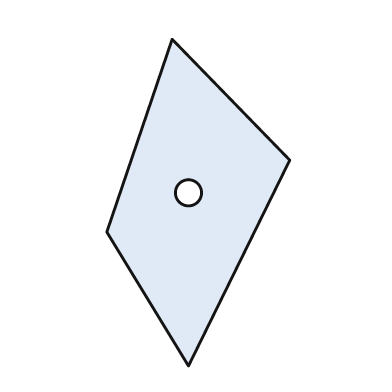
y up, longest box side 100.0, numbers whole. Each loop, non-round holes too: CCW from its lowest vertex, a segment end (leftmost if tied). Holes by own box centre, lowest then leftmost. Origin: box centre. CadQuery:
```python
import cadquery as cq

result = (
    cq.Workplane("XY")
    .moveTo(-3.0, -50.0)
    .lineTo(28.0, 13.0)
    .lineTo(-8.0, 50.0)
    .lineTo(-28.0, -9.0)
    .close()
    .moveTo(-3.0, 3.0)
    .circle(4.0)
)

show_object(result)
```